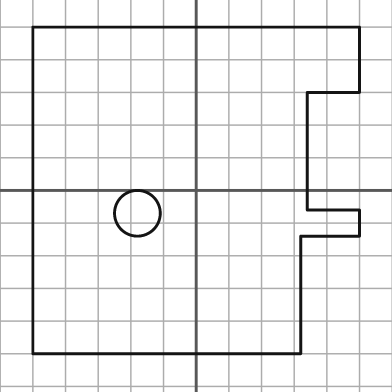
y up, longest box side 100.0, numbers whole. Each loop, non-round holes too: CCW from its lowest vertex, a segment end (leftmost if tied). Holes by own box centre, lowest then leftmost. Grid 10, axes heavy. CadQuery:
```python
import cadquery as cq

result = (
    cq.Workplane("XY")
    .moveTo(-50.0, -50.0)
    .lineTo(32.0, -50.0)
    .lineTo(32.0, -14.0)
    .lineTo(50.0, -14.0)
    .lineTo(50.0, -6.0)
    .lineTo(34.0, -6.0)
    .lineTo(34.0, 30.0)
    .lineTo(50.0, 30.0)
    .lineTo(50.0, 50.0)
    .lineTo(-50.0, 50.0)
    .close()
    .moveTo(-18.0, -7.0)
    .circle(7.0)
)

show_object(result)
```